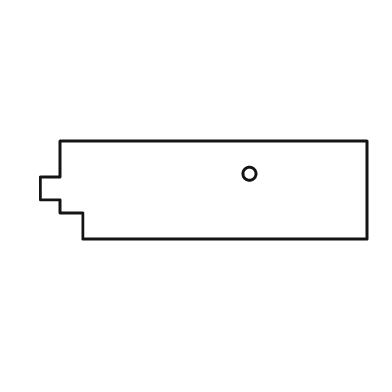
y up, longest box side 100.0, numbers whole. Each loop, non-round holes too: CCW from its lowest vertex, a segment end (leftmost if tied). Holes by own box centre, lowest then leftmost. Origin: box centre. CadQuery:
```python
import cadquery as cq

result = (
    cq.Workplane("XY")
    .moveTo(-37.0, -15.0)
    .lineTo(50.0, -15.0)
    .lineTo(50.0, 15.0)
    .lineTo(-44.0, 15.0)
    .lineTo(-44.0, 4.0)
    .lineTo(-50.0, 4.0)
    .lineTo(-50.0, -3.0)
    .lineTo(-44.0, -3.0)
    .lineTo(-44.0, -7.0)
    .lineTo(-37.0, -7.0)
    .close()
    .moveTo(14.0, 5.0)
    .circle(2.0)
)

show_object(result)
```